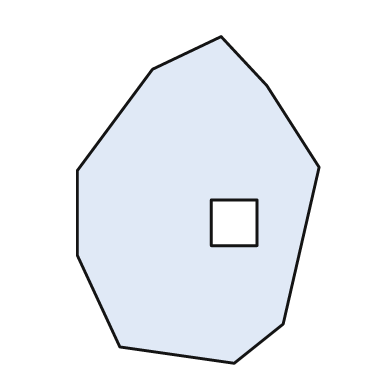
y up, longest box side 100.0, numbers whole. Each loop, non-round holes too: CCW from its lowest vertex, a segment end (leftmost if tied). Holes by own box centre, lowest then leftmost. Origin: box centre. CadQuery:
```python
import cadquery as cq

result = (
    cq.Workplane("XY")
    .moveTo(11.0, -50.0)
    .lineTo(26.0, -38.0)
    .lineTo(37.0, 10.0)
    .lineTo(21.0, 35.0)
    .lineTo(7.0, 50.0)
    .lineTo(-14.0, 40.0)
    .lineTo(-37.0, 9.0)
    .lineTo(-37.0, -17.0)
    .lineTo(-24.0, -45.0)
    .close()
    .moveTo(4.0, -14.0)
    .lineTo(18.0, -14.0)
    .lineTo(18.0, 0.0)
    .lineTo(4.0, 0.0)
    .close()
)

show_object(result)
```